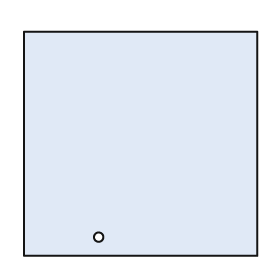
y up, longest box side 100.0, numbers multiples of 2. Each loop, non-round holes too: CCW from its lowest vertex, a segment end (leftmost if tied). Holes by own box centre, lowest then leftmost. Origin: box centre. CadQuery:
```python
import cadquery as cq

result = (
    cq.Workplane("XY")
    .moveTo(-50.0, -48.0)
    .lineTo(50.0, -48.0)
    .lineTo(50.0, 48.0)
    .lineTo(-50.0, 48.0)
    .close()
    .moveTo(-18.0, -40.0)
    .circle(2.0)
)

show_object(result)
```